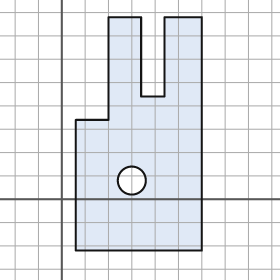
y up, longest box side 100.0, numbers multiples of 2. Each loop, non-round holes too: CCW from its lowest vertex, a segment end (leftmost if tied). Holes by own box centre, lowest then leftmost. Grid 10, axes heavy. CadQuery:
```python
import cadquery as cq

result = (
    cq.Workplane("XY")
    .moveTo(6.0, -22.0)
    .lineTo(60.0, -22.0)
    .lineTo(60.0, 78.0)
    .lineTo(44.0, 78.0)
    .lineTo(44.0, 44.0)
    .lineTo(34.0, 44.0)
    .lineTo(34.0, 78.0)
    .lineTo(20.0, 78.0)
    .lineTo(20.0, 34.0)
    .lineTo(6.0, 34.0)
    .close()
    .moveTo(30.0, 8.0)
    .circle(6.0)
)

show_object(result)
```